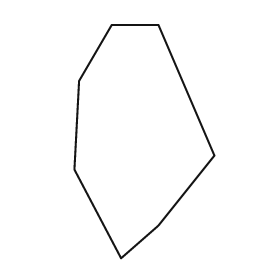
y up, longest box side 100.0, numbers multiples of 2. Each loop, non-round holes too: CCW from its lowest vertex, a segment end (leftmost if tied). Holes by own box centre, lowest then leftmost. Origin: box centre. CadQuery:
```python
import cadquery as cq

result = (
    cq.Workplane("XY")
    .moveTo(-10.0, -50.0)
    .lineTo(6.0, -36.0)
    .lineTo(30.0, -6.0)
    .lineTo(6.0, 50.0)
    .lineTo(-14.0, 50.0)
    .lineTo(-28.0, 26.0)
    .lineTo(-30.0, -12.0)
    .close()
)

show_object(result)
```